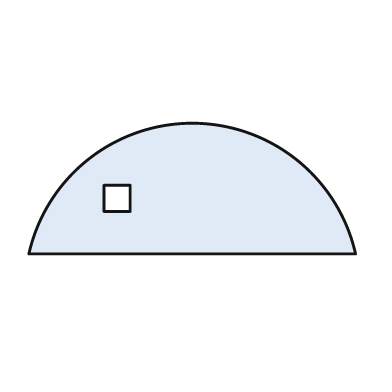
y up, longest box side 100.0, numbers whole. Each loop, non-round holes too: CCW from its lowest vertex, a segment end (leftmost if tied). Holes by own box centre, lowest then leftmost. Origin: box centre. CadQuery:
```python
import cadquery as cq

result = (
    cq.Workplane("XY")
    .moveTo(-50.0, -20.0)
    .lineTo(50.0, -20.0)
    .threePointArc((0.0, 20.0), (-50.0, -20.0))
    .close()
    .moveTo(-27.0, -7.0)
    .lineTo(-19.0, -7.0)
    .lineTo(-19.0, 1.0)
    .lineTo(-27.0, 1.0)
    .close()
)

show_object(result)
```